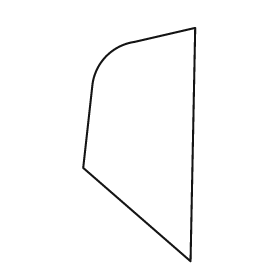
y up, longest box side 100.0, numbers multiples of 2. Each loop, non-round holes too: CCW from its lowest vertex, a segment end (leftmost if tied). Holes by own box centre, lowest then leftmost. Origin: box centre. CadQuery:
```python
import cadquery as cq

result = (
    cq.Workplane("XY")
    .moveTo(22.0, -50.0)
    .lineTo(24.0, 50.0)
    .lineTo(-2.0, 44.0)
    .threePointArc((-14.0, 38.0), (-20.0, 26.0))
    .lineTo(-24.0, -10.0)
    .close()
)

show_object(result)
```